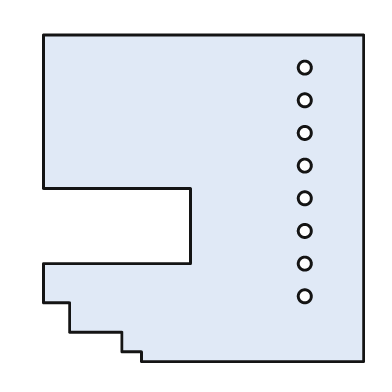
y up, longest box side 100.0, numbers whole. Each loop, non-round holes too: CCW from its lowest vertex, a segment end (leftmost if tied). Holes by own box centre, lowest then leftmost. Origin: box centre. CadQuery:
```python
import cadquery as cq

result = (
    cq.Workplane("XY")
    .moveTo(-19.0, -50.0)
    .lineTo(49.0, -50.0)
    .lineTo(49.0, 50.0)
    .lineTo(-49.0, 50.0)
    .lineTo(-49.0, 3.0)
    .lineTo(-4.0, 3.0)
    .lineTo(-4.0, -20.0)
    .lineTo(-49.0, -20.0)
    .lineTo(-49.0, -32.0)
    .lineTo(-41.0, -32.0)
    .lineTo(-41.0, -41.0)
    .lineTo(-25.0, -41.0)
    .lineTo(-25.0, -47.0)
    .lineTo(-19.0, -47.0)
    .close()
    .moveTo(31.0, -30.0)
    .circle(2.0)
    .moveTo(31.0, -20.0)
    .circle(2.0)
    .moveTo(31.0, -10.0)
    .circle(2.0)
    .moveTo(31.0, 0.0)
    .circle(2.0)
    .moveTo(31.0, 10.0)
    .circle(2.0)
    .moveTo(31.0, 20.0)
    .circle(2.0)
    .moveTo(31.0, 30.0)
    .circle(2.0)
    .moveTo(31.0, 40.0)
    .circle(2.0)
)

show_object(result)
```